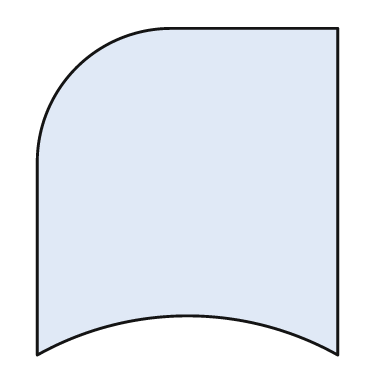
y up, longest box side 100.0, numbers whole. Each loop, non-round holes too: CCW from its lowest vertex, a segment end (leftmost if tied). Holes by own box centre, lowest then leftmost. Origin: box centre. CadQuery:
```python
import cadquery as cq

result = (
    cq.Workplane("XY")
    .moveTo(-46.0, -50.0)
    .threePointArc((0.0, -38.0), (46.0, -50.0))
    .lineTo(46.0, 50.0)
    .lineTo(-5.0, 50.0)
    .threePointArc((-34.0, 38.0), (-46.0, 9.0))
    .close()
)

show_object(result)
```